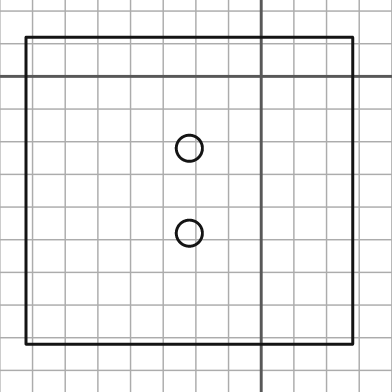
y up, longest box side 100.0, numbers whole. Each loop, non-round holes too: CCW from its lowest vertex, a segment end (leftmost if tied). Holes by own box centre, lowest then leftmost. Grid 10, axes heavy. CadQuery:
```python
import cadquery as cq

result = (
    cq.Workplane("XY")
    .moveTo(-72.0, -82.0)
    .lineTo(28.0, -82.0)
    .lineTo(28.0, 12.0)
    .lineTo(-72.0, 12.0)
    .close()
    .moveTo(-22.0, -48.0)
    .circle(4.0)
    .moveTo(-22.0, -22.0)
    .circle(4.0)
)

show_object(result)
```